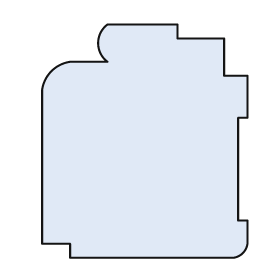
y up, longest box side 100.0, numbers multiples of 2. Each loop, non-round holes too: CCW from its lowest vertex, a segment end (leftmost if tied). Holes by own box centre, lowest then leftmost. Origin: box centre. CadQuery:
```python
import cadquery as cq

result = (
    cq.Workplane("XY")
    .moveTo(-32.0, -50.0)
    .lineTo(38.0, -50.0)
    .threePointArc((42.0, -48.0), (44.0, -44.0))
    .lineTo(44.0, -34.0)
    .lineTo(40.0, -34.0)
    .lineTo(40.0, 10.0)
    .lineTo(44.0, 10.0)
    .lineTo(44.0, 28.0)
    .lineTo(34.0, 28.0)
    .lineTo(34.0, 44.0)
    .lineTo(14.0, 44.0)
    .lineTo(14.0, 50.0)
    .lineTo(-16.0, 50.0)
    .threePointArc((-20.0, 42.0), (-16.0, 34.0))
    .lineTo(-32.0, 34.0)
    .threePointArc((-40.0, 30.0), (-44.0, 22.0))
    .lineTo(-44.0, -44.0)
    .lineTo(-32.0, -44.0)
    .close()
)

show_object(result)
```